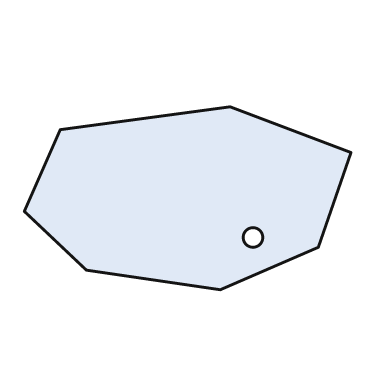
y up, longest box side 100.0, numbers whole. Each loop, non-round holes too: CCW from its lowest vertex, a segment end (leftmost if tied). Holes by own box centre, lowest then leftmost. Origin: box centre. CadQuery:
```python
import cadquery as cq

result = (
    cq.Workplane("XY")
    .moveTo(10.0, -28.0)
    .lineTo(40.0, -15.0)
    .lineTo(50.0, 14.0)
    .lineTo(13.0, 28.0)
    .lineTo(-39.0, 21.0)
    .lineTo(-50.0, -4.0)
    .lineTo(-31.0, -22.0)
    .close()
    .moveTo(20.0, -12.0)
    .circle(3.0)
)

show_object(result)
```